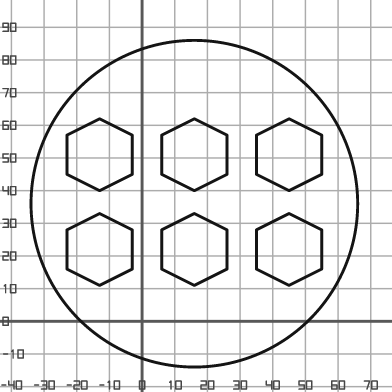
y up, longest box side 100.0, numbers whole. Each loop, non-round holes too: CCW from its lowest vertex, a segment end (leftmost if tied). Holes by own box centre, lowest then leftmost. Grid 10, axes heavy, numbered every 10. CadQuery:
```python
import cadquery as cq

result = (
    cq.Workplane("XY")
    .moveTo(16.0, 36.0)
    .circle(50.0)
    .moveTo(-13.0, 11.0)
    .lineTo(-3.0, 16.0)
    .lineTo(-3.0, 28.0)
    .lineTo(-13.0, 33.0)
    .lineTo(-23.0, 28.0)
    .lineTo(-23.0, 16.0)
    .close()
    .moveTo(16.0, 11.0)
    .lineTo(26.0, 16.0)
    .lineTo(26.0, 28.0)
    .lineTo(16.0, 33.0)
    .lineTo(6.0, 28.0)
    .lineTo(6.0, 16.0)
    .close()
    .moveTo(45.0, 11.0)
    .lineTo(55.0, 16.0)
    .lineTo(55.0, 28.0)
    .lineTo(45.0, 33.0)
    .lineTo(35.0, 28.0)
    .lineTo(35.0, 16.0)
    .close()
    .moveTo(-13.0, 40.0)
    .lineTo(-3.0, 45.0)
    .lineTo(-3.0, 57.0)
    .lineTo(-13.0, 62.0)
    .lineTo(-23.0, 57.0)
    .lineTo(-23.0, 45.0)
    .close()
    .moveTo(16.0, 40.0)
    .lineTo(26.0, 45.0)
    .lineTo(26.0, 57.0)
    .lineTo(16.0, 62.0)
    .lineTo(6.0, 57.0)
    .lineTo(6.0, 45.0)
    .close()
    .moveTo(45.0, 40.0)
    .lineTo(55.0, 45.0)
    .lineTo(55.0, 57.0)
    .lineTo(45.0, 62.0)
    .lineTo(35.0, 57.0)
    .lineTo(35.0, 45.0)
    .close()
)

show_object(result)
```